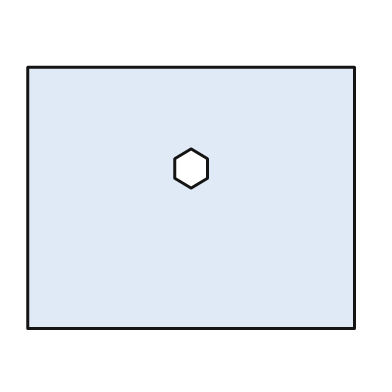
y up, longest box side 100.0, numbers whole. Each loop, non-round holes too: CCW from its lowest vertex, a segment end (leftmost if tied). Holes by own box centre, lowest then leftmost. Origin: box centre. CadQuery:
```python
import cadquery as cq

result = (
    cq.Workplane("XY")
    .moveTo(-50.0, -40.0)
    .lineTo(50.0, -40.0)
    .lineTo(50.0, 40.0)
    .lineTo(-50.0, 40.0)
    .close()
    .moveTo(0.0, 3.0)
    .lineTo(5.0, 6.0)
    .lineTo(5.0, 12.0)
    .lineTo(0.0, 15.0)
    .lineTo(-5.0, 12.0)
    .lineTo(-5.0, 6.0)
    .close()
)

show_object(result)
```